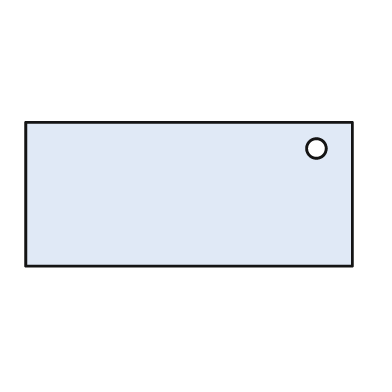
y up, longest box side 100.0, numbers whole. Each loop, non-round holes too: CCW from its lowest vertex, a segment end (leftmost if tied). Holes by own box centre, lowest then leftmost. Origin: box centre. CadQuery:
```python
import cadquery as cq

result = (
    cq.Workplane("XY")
    .moveTo(-50.0, -22.0)
    .lineTo(50.0, -22.0)
    .lineTo(50.0, 22.0)
    .lineTo(-50.0, 22.0)
    .close()
    .moveTo(39.0, 14.0)
    .circle(3.0)
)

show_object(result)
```